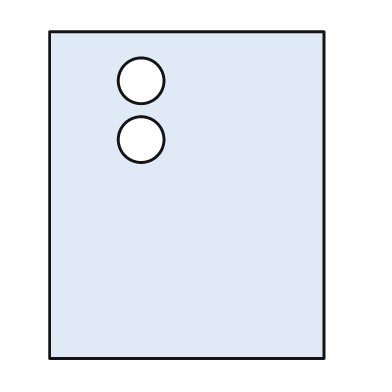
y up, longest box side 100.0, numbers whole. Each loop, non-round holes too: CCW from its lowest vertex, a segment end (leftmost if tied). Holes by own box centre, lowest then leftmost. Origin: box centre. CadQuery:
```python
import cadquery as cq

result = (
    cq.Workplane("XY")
    .moveTo(-42.0, -50.0)
    .lineTo(42.0, -50.0)
    .lineTo(42.0, 50.0)
    .lineTo(-42.0, 50.0)
    .close()
    .moveTo(-14.0, 17.0)
    .circle(7.0)
    .moveTo(-14.0, 35.0)
    .circle(7.0)
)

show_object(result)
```